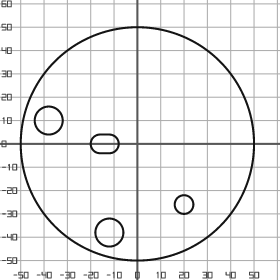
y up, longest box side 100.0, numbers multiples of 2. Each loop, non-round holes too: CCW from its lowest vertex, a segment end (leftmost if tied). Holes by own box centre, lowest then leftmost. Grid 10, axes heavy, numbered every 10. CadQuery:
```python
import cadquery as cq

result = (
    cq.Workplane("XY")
    .moveTo(0.0, 0.0)
    .circle(50.0)
    .moveTo(-12.0, -38.0)
    .circle(6.0)
    .moveTo(20.0, -26.0)
    .circle(4.0)
    .moveTo(-16.0, -4.0)
    .lineTo(-12.0, -4.0)
    .threePointArc((-8.0, 0.0), (-12.0, 4.0))
    .lineTo(-16.0, 4.0)
    .threePointArc((-20.0, 0.0), (-16.0, -4.0))
    .close()
    .moveTo(-38.0, 10.0)
    .circle(6.0)
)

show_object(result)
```